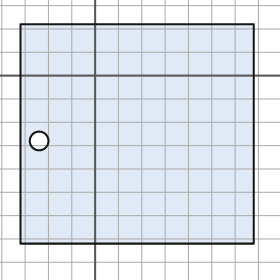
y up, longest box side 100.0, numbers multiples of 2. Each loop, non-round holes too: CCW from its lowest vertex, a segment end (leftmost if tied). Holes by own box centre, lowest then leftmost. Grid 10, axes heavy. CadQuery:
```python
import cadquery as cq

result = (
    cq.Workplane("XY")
    .moveTo(-32.0, -72.0)
    .lineTo(68.0, -72.0)
    .lineTo(68.0, 22.0)
    .lineTo(-32.0, 22.0)
    .close()
    .moveTo(-24.0, -28.0)
    .circle(4.0)
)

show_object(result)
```